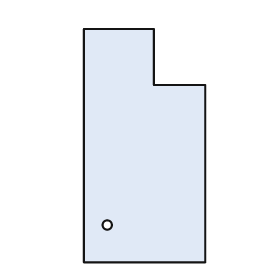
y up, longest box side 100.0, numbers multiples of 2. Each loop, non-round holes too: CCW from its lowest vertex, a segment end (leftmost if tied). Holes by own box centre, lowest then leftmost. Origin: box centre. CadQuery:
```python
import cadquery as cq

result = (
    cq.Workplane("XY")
    .moveTo(-26.0, -50.0)
    .lineTo(26.0, -50.0)
    .lineTo(26.0, 26.0)
    .lineTo(4.0, 26.0)
    .lineTo(4.0, 50.0)
    .lineTo(-26.0, 50.0)
    .close()
    .moveTo(-16.0, -34.0)
    .circle(2.0)
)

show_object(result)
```